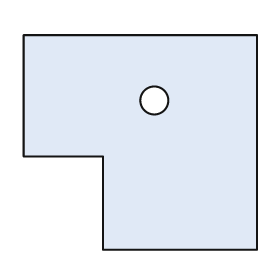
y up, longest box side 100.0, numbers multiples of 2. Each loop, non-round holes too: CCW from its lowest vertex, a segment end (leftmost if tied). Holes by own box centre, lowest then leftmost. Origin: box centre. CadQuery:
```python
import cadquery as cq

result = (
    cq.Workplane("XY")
    .moveTo(-16.0, -46.0)
    .lineTo(50.0, -46.0)
    .lineTo(50.0, 46.0)
    .lineTo(-50.0, 46.0)
    .lineTo(-50.0, -6.0)
    .lineTo(-16.0, -6.0)
    .close()
    .moveTo(6.0, 18.0)
    .circle(6.0)
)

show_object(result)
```